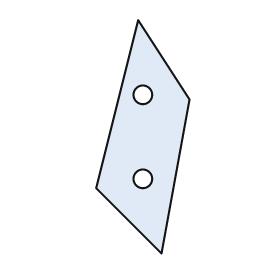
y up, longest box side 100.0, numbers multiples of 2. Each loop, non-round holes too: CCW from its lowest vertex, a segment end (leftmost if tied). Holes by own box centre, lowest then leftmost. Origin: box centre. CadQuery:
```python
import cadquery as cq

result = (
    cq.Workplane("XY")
    .moveTo(8.0, -50.0)
    .lineTo(20.0, 16.0)
    .lineTo(-2.0, 50.0)
    .lineTo(-20.0, -22.0)
    .close()
    .moveTo(0.0, -18.0)
    .circle(4.0)
    .moveTo(0.0, 18.0)
    .circle(4.0)
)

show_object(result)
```